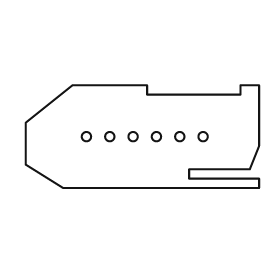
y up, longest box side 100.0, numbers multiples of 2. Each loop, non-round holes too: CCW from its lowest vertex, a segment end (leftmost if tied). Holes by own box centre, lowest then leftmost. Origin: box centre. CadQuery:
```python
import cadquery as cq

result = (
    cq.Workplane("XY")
    .moveTo(-34.0, -22.0)
    .lineTo(50.0, -22.0)
    .lineTo(50.0, -18.0)
    .lineTo(20.0, -18.0)
    .lineTo(20.0, -14.0)
    .lineTo(46.0, -14.0)
    .lineTo(50.0, -4.0)
    .lineTo(50.0, 22.0)
    .lineTo(42.0, 22.0)
    .lineTo(42.0, 18.0)
    .lineTo(2.0, 18.0)
    .lineTo(2.0, 22.0)
    .lineTo(-30.0, 22.0)
    .lineTo(-50.0, 6.0)
    .lineTo(-50.0, -12.0)
    .close()
    .moveTo(-24.0, 0.0)
    .circle(2.0)
    .moveTo(-14.0, 0.0)
    .circle(2.0)
    .moveTo(-4.0, 0.0)
    .circle(2.0)
    .moveTo(6.0, 0.0)
    .circle(2.0)
    .moveTo(16.0, 0.0)
    .circle(2.0)
    .moveTo(26.0, 0.0)
    .circle(2.0)
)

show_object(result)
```